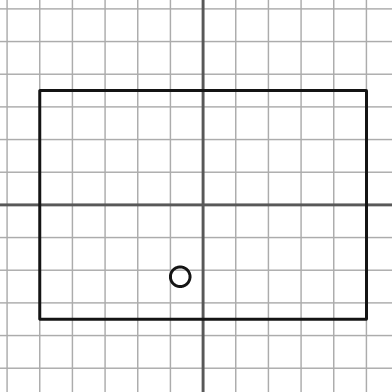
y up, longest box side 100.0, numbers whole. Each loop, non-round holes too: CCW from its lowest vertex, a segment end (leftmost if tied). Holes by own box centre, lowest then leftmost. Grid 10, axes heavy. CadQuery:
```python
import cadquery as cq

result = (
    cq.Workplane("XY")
    .moveTo(-50.0, -35.0)
    .lineTo(50.0, -35.0)
    .lineTo(50.0, 35.0)
    .lineTo(-50.0, 35.0)
    .close()
    .moveTo(-7.0, -22.0)
    .circle(3.0)
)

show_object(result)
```